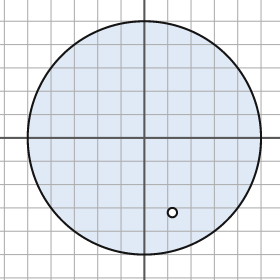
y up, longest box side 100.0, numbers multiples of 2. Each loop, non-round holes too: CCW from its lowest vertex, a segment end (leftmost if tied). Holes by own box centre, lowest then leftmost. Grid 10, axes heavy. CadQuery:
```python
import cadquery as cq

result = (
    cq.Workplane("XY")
    .moveTo(0.0, 0.0)
    .circle(50.0)
    .moveTo(12.0, -32.0)
    .circle(2.0)
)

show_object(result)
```